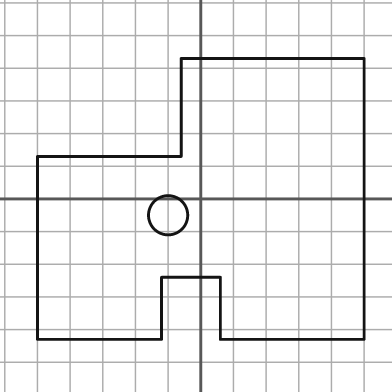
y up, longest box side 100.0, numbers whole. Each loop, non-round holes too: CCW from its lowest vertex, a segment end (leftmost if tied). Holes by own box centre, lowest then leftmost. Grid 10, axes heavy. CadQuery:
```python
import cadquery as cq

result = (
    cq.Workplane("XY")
    .moveTo(-50.0, -43.0)
    .lineTo(-12.0, -43.0)
    .lineTo(-12.0, -24.0)
    .lineTo(6.0, -24.0)
    .lineTo(6.0, -43.0)
    .lineTo(50.0, -43.0)
    .lineTo(50.0, 43.0)
    .lineTo(-6.0, 43.0)
    .lineTo(-6.0, 13.0)
    .lineTo(-50.0, 13.0)
    .close()
    .moveTo(-10.0, -5.0)
    .circle(6.0)
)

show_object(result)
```